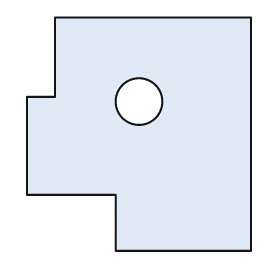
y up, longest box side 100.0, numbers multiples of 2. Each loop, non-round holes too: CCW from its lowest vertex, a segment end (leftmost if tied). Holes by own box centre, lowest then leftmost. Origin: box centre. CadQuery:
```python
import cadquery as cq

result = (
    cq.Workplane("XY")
    .moveTo(-10.0, -50.0)
    .lineTo(48.0, -50.0)
    .lineTo(48.0, 50.0)
    .lineTo(-36.0, 50.0)
    .lineTo(-36.0, 16.0)
    .lineTo(-48.0, 16.0)
    .lineTo(-48.0, -26.0)
    .lineTo(-10.0, -26.0)
    .close()
    .moveTo(0.0, 14.0)
    .circle(10.0)
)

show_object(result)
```